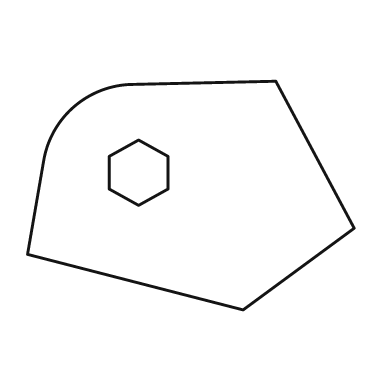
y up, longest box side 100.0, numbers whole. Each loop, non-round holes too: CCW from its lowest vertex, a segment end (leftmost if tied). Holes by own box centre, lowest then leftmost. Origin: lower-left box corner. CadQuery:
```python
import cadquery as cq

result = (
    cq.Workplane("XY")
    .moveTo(66.0, 0.0)
    .lineTo(100.0, 25.0)
    .lineTo(76.0, 70.0)
    .lineTo(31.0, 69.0)
    .threePointArc((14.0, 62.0), (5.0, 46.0))
    .lineTo(0.0, 17.0)
    .close()
    .moveTo(34.0, 32.0)
    .lineTo(43.0, 37.0)
    .lineTo(43.0, 47.0)
    .lineTo(34.0, 52.0)
    .lineTo(25.0, 47.0)
    .lineTo(25.0, 37.0)
    .close()
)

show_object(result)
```